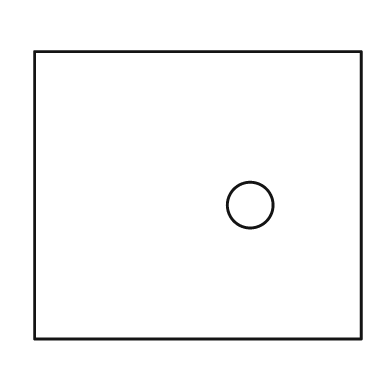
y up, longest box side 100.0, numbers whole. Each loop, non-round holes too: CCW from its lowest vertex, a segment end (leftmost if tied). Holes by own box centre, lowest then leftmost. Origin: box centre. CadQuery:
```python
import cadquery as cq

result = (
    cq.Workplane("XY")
    .moveTo(-50.0, -44.0)
    .lineTo(50.0, -44.0)
    .lineTo(50.0, 44.0)
    .lineTo(-50.0, 44.0)
    .close()
    .moveTo(16.0, -3.0)
    .circle(7.0)
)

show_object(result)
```